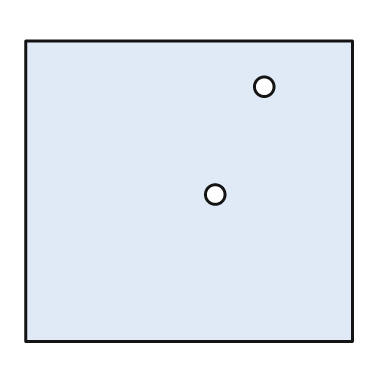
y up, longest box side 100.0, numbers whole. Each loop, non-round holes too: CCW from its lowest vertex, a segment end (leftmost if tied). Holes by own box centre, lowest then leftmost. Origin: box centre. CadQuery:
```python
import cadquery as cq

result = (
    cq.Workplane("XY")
    .moveTo(-50.0, -46.0)
    .lineTo(50.0, -46.0)
    .lineTo(50.0, 46.0)
    .lineTo(-50.0, 46.0)
    .close()
    .moveTo(8.0, -1.0)
    .circle(3.0)
    .moveTo(23.0, 32.0)
    .circle(3.0)
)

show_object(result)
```